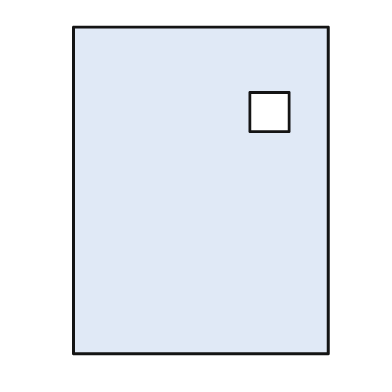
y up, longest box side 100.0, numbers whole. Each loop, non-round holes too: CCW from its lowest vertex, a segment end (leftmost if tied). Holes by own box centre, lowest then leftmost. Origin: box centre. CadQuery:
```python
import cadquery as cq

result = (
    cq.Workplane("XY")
    .moveTo(-39.0, -50.0)
    .lineTo(39.0, -50.0)
    .lineTo(39.0, 50.0)
    .lineTo(-39.0, 50.0)
    .close()
    .moveTo(15.0, 18.0)
    .lineTo(27.0, 18.0)
    .lineTo(27.0, 30.0)
    .lineTo(15.0, 30.0)
    .close()
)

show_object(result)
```